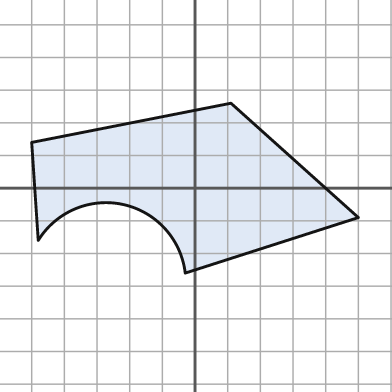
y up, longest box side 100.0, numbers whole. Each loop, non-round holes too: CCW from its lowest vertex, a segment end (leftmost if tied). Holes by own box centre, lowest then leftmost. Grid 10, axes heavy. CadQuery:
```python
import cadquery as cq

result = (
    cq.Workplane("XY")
    .moveTo(-3.0, -26.0)
    .lineTo(50.0, -9.0)
    .lineTo(11.0, 26.0)
    .lineTo(-50.0, 14.0)
    .lineTo(-48.0, -16.0)
    .threePointArc((-22.0, -5.0), (-3.0, -26.0))
    .close()
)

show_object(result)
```